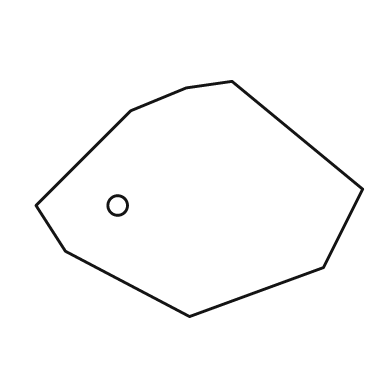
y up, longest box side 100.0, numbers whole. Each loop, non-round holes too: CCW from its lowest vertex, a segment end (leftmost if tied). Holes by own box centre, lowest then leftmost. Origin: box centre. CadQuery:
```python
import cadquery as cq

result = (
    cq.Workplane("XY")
    .moveTo(-3.0, -36.0)
    .lineTo(38.0, -21.0)
    .lineTo(50.0, 3.0)
    .lineTo(10.0, 36.0)
    .lineTo(-4.0, 34.0)
    .lineTo(-21.0, 27.0)
    .lineTo(-50.0, -2.0)
    .lineTo(-41.0, -16.0)
    .close()
    .moveTo(-25.0, -2.0)
    .circle(3.0)
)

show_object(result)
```